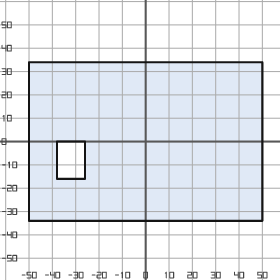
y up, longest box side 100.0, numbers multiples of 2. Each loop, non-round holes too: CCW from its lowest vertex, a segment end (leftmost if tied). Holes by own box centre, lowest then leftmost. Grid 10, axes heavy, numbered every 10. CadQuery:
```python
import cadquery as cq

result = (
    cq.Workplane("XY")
    .moveTo(-50.0, -34.0)
    .lineTo(50.0, -34.0)
    .lineTo(50.0, 34.0)
    .lineTo(-50.0, 34.0)
    .close()
    .moveTo(-38.0, -16.0)
    .lineTo(-26.0, -16.0)
    .lineTo(-26.0, 0.0)
    .lineTo(-38.0, 0.0)
    .close()
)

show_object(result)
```